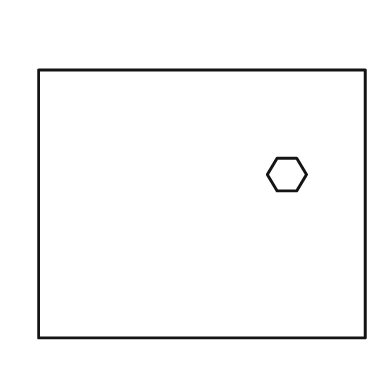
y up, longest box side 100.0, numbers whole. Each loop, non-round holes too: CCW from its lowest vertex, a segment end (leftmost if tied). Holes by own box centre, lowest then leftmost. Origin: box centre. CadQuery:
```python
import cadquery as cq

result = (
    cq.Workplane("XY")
    .moveTo(-50.0, -41.0)
    .lineTo(50.0, -41.0)
    .lineTo(50.0, 41.0)
    .lineTo(-50.0, 41.0)
    .close()
    .moveTo(23.0, 4.0)
    .lineTo(29.0, 4.0)
    .lineTo(32.0, 9.0)
    .lineTo(29.0, 14.0)
    .lineTo(23.0, 14.0)
    .lineTo(20.0, 9.0)
    .close()
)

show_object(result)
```